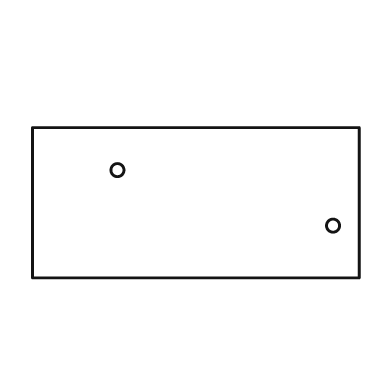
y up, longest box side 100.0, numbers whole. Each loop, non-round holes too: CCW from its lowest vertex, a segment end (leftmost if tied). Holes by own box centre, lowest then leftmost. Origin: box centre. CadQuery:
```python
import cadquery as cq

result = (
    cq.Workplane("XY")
    .moveTo(-50.0, -23.0)
    .lineTo(50.0, -23.0)
    .lineTo(50.0, 23.0)
    .lineTo(-50.0, 23.0)
    .close()
    .moveTo(42.0, -7.0)
    .circle(2.0)
    .moveTo(-24.0, 10.0)
    .circle(2.0)
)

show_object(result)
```